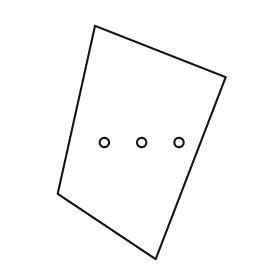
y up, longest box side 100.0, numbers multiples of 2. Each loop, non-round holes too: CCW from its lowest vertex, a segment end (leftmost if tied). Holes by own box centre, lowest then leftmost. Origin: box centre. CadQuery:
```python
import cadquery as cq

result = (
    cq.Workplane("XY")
    .moveTo(6.0, -50.0)
    .lineTo(36.0, 28.0)
    .lineTo(-20.0, 50.0)
    .lineTo(-36.0, -22.0)
    .close()
    .moveTo(-16.0, 0.0)
    .circle(2.0)
    .moveTo(0.0, 0.0)
    .circle(2.0)
    .moveTo(16.0, 0.0)
    .circle(2.0)
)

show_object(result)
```